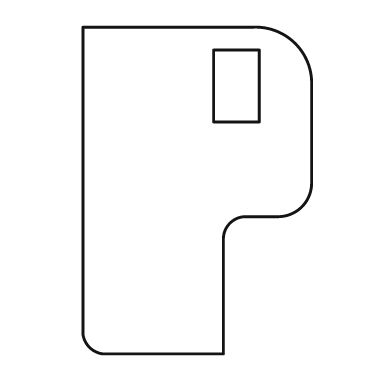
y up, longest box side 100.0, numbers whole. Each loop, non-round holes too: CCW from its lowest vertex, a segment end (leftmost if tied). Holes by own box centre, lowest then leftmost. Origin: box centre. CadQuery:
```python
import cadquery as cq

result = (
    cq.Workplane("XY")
    .moveTo(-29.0, -50.0)
    .lineTo(8.0, -50.0)
    .lineTo(8.0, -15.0)
    .threePointArc((10.0, -10.0), (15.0, -8.0))
    .lineTo(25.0, -8.0)
    .threePointArc((32.0, -5.0), (35.0, 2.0))
    .lineTo(35.0, 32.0)
    .threePointArc((30.0, 45.0), (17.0, 50.0))
    .lineTo(-35.0, 50.0)
    .lineTo(-35.0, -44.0)
    .threePointArc((-33.0, -48.0), (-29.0, -50.0))
    .close()
    .moveTo(5.0, 21.0)
    .lineTo(19.0, 21.0)
    .lineTo(19.0, 43.0)
    .lineTo(5.0, 43.0)
    .close()
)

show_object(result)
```